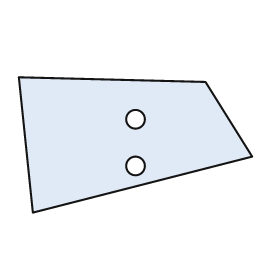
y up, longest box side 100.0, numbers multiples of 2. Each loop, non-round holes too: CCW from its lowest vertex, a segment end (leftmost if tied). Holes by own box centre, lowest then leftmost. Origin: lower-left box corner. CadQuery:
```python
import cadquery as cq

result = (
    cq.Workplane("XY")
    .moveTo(6.0, 0.0)
    .lineTo(100.0, 24.0)
    .lineTo(80.0, 56.0)
    .lineTo(0.0, 58.0)
    .close()
    .moveTo(50.0, 20.0)
    .circle(4.0)
    .moveTo(50.0, 40.0)
    .circle(4.0)
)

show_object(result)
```